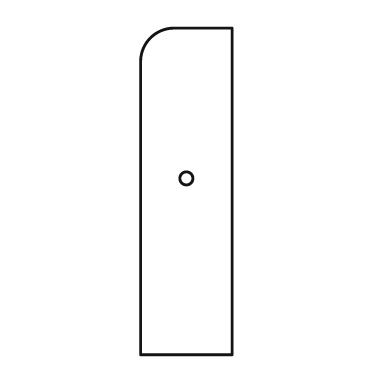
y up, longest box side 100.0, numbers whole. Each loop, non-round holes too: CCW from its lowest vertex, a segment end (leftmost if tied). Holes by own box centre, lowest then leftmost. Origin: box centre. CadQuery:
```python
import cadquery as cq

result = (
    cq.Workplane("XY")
    .moveTo(-14.0, -50.0)
    .lineTo(14.0, -50.0)
    .lineTo(14.0, 50.0)
    .lineTo(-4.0, 50.0)
    .threePointArc((-11.0, 47.0), (-14.0, 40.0))
    .close()
    .moveTo(0.0, 4.0)
    .circle(2.0)
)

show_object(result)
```